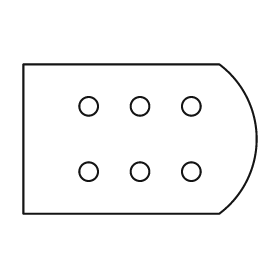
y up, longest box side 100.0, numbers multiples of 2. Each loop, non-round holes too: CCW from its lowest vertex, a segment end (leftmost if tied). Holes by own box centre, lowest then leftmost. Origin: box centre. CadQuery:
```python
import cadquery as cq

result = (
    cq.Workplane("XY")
    .moveTo(-50.0, -32.0)
    .lineTo(34.0, -32.0)
    .threePointArc((50.0, 0.0), (34.0, 32.0))
    .lineTo(-50.0, 32.0)
    .close()
    .moveTo(-22.0, -14.0)
    .circle(4.0)
    .moveTo(0.0, -14.0)
    .circle(4.0)
    .moveTo(22.0, -14.0)
    .circle(4.0)
    .moveTo(-22.0, 14.0)
    .circle(4.0)
    .moveTo(0.0, 14.0)
    .circle(4.0)
    .moveTo(22.0, 14.0)
    .circle(4.0)
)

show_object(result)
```